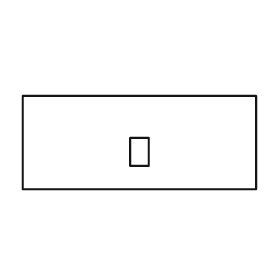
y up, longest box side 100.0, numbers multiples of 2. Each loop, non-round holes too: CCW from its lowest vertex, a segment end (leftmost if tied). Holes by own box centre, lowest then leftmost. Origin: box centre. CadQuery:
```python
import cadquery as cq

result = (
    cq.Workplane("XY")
    .moveTo(-50.0, -20.0)
    .lineTo(50.0, -20.0)
    .lineTo(50.0, 20.0)
    .lineTo(-50.0, 20.0)
    .close()
    .moveTo(-4.0, -10.0)
    .lineTo(4.0, -10.0)
    .lineTo(4.0, 2.0)
    .lineTo(-4.0, 2.0)
    .close()
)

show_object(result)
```